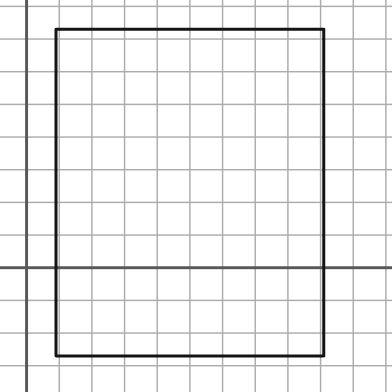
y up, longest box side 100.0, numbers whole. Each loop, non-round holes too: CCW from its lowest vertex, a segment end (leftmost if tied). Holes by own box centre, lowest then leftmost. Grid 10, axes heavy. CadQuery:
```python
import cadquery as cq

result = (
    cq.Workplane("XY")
    .moveTo(9.0, -27.0)
    .lineTo(91.0, -27.0)
    .lineTo(91.0, 73.0)
    .lineTo(9.0, 73.0)
    .close()
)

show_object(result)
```